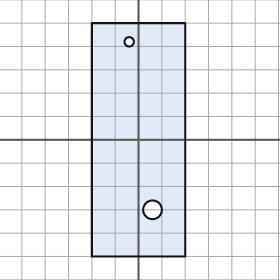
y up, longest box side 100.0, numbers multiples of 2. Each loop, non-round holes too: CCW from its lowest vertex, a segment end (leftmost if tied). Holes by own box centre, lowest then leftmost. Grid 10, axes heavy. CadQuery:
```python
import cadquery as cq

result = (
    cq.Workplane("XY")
    .moveTo(-20.0, -50.0)
    .lineTo(20.0, -50.0)
    .lineTo(20.0, 50.0)
    .lineTo(-20.0, 50.0)
    .close()
    .moveTo(6.0, -30.0)
    .circle(4.0)
    .moveTo(-4.0, 42.0)
    .circle(2.0)
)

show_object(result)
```